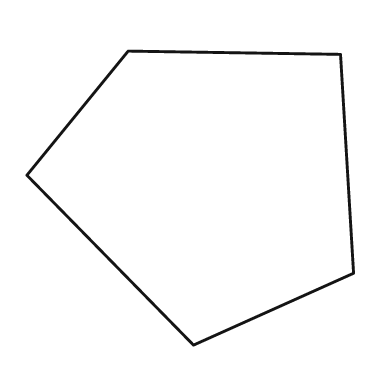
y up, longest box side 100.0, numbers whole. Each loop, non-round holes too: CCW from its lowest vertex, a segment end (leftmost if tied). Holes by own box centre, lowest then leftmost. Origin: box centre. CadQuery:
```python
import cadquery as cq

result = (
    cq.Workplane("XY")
    .moveTo(1.0, -45.0)
    .lineTo(50.0, -23.0)
    .lineTo(46.0, 44.0)
    .lineTo(-19.0, 45.0)
    .lineTo(-50.0, 7.0)
    .close()
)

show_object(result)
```